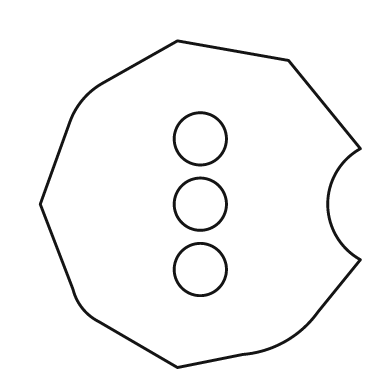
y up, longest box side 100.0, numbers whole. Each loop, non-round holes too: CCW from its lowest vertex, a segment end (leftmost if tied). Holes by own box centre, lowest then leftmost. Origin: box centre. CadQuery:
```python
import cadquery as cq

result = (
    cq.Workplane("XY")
    .moveTo(-7.0, -50.0)
    .lineTo(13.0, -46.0)
    .threePointArc((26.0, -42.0), (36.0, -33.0))
    .lineTo(49.0, -17.0)
    .threePointArc((39.0, 0.0), (49.0, 17.0))
    .lineTo(27.0, 44.0)
    .lineTo(-7.0, 50.0)
    .lineTo(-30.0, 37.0)
    .threePointArc((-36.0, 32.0), (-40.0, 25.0))
    .lineTo(-49.0, 0.0)
    .lineTo(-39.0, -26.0)
    .threePointArc((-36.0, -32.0), (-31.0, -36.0))
    .close()
    .moveTo(0.0, -20.0)
    .circle(8.0)
    .moveTo(0.0, 0.0)
    .circle(8.0)
    .moveTo(0.0, 20.0)
    .circle(8.0)
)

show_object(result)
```